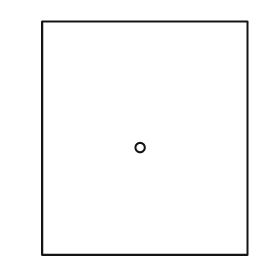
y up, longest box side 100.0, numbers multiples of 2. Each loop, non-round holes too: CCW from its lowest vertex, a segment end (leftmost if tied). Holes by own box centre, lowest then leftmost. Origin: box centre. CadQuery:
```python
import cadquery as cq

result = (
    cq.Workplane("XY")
    .moveTo(-44.0, -50.0)
    .lineTo(44.0, -50.0)
    .lineTo(44.0, 50.0)
    .lineTo(-44.0, 50.0)
    .close()
    .moveTo(-2.0, -4.0)
    .circle(2.0)
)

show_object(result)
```